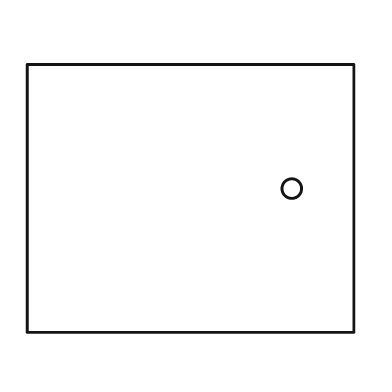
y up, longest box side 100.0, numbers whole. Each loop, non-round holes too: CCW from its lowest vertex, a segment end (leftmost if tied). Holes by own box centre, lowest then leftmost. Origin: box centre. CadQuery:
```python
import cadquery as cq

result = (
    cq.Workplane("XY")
    .moveTo(-50.0, -41.0)
    .lineTo(50.0, -41.0)
    .lineTo(50.0, 41.0)
    .lineTo(-50.0, 41.0)
    .close()
    .moveTo(31.0, 3.0)
    .circle(3.0)
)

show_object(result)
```